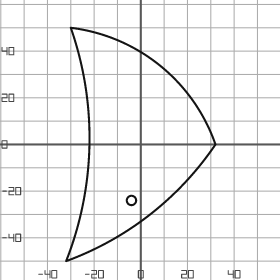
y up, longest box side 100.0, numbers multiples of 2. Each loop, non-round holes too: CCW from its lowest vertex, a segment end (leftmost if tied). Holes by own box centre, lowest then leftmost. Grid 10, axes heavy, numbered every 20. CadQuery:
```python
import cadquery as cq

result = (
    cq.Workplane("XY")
    .moveTo(-32.0, -50.0)
    .threePointArc((4.0, -30.0), (32.0, 0.0))
    .threePointArc((8.0, 34.0), (-30.0, 50.0))
    .threePointArc((-22.0, 0.0), (-32.0, -50.0))
    .close()
    .moveTo(-4.0, -24.0)
    .circle(2.0)
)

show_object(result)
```